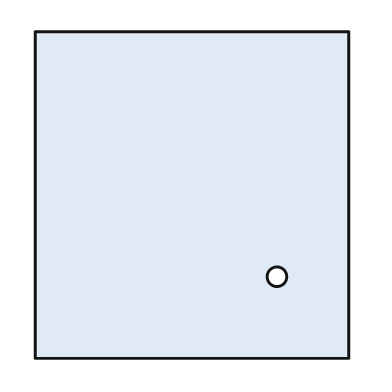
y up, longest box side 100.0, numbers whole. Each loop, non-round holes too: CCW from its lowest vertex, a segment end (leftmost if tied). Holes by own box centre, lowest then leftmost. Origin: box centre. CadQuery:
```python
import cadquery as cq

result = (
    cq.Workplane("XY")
    .moveTo(-48.0, -50.0)
    .lineTo(48.0, -50.0)
    .lineTo(48.0, 50.0)
    .lineTo(-48.0, 50.0)
    .close()
    .moveTo(26.0, -25.0)
    .circle(3.0)
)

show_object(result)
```